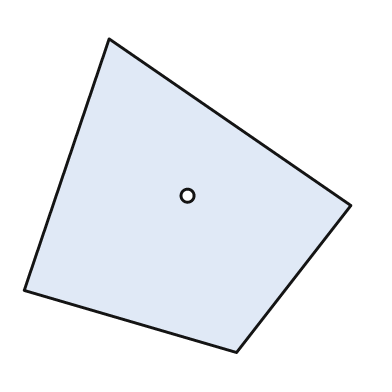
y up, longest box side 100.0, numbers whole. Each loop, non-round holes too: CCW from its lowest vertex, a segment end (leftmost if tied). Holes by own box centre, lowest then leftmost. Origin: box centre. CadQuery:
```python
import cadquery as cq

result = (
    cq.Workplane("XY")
    .moveTo(15.0, -48.0)
    .lineTo(50.0, -3.0)
    .lineTo(-24.0, 48.0)
    .lineTo(-50.0, -29.0)
    .close()
    .moveTo(0.0, 0.0)
    .circle(2.0)
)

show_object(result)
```